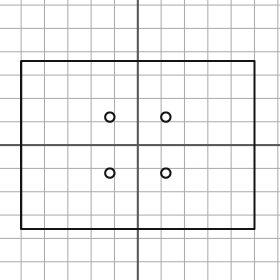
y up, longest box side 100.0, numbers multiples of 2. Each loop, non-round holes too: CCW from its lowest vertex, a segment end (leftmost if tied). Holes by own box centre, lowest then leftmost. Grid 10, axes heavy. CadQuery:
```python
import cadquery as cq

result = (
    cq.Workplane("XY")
    .moveTo(-50.0, -36.0)
    .lineTo(50.0, -36.0)
    .lineTo(50.0, 36.0)
    .lineTo(-50.0, 36.0)
    .close()
    .moveTo(-12.0, -12.0)
    .circle(2.0)
    .moveTo(12.0, -12.0)
    .circle(2.0)
    .moveTo(-12.0, 12.0)
    .circle(2.0)
    .moveTo(12.0, 12.0)
    .circle(2.0)
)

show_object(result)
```